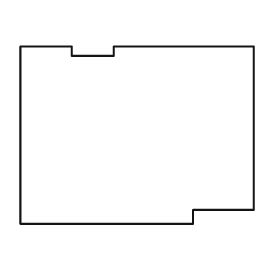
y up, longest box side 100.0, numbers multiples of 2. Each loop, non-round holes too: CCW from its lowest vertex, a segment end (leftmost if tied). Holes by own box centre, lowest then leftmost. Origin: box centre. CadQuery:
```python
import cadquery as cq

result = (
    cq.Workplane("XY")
    .moveTo(-50.0, -38.0)
    .lineTo(24.0, -38.0)
    .lineTo(24.0, -32.0)
    .lineTo(50.0, -32.0)
    .lineTo(50.0, 38.0)
    .lineTo(-10.0, 38.0)
    .lineTo(-10.0, 34.0)
    .lineTo(-28.0, 34.0)
    .lineTo(-28.0, 38.0)
    .lineTo(-50.0, 38.0)
    .close()
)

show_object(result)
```